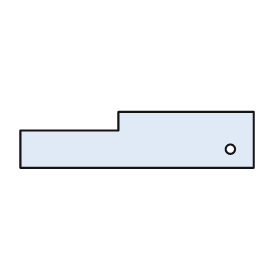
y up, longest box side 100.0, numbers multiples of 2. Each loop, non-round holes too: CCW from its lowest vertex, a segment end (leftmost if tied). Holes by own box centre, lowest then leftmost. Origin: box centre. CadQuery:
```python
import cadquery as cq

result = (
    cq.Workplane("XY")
    .moveTo(-50.0, -12.0)
    .lineTo(50.0, -12.0)
    .lineTo(50.0, 12.0)
    .lineTo(-8.0, 12.0)
    .lineTo(-8.0, 4.0)
    .lineTo(-50.0, 4.0)
    .close()
    .moveTo(40.0, -4.0)
    .circle(2.0)
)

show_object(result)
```